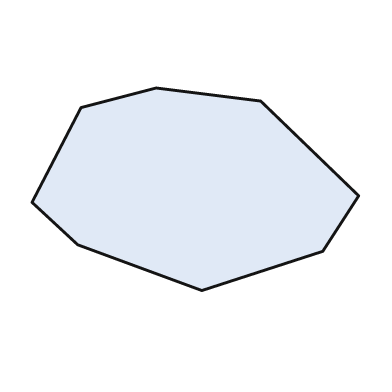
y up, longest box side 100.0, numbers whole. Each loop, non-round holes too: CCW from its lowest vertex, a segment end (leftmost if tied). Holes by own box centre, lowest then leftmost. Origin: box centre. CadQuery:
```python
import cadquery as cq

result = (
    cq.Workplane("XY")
    .moveTo(2.0, -31.0)
    .lineTo(39.0, -19.0)
    .lineTo(50.0, -2.0)
    .lineTo(20.0, 27.0)
    .lineTo(-12.0, 31.0)
    .lineTo(-35.0, 25.0)
    .lineTo(-50.0, -4.0)
    .lineTo(-36.0, -17.0)
    .close()
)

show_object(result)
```